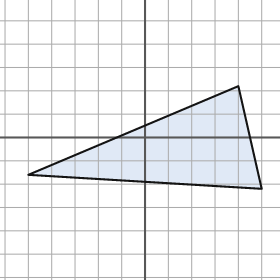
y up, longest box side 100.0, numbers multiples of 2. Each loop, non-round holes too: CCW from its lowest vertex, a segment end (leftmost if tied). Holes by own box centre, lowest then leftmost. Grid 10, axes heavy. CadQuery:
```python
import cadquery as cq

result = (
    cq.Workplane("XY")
    .moveTo(50.0, -22.0)
    .lineTo(40.0, 22.0)
    .lineTo(-50.0, -16.0)
    .close()
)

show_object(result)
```